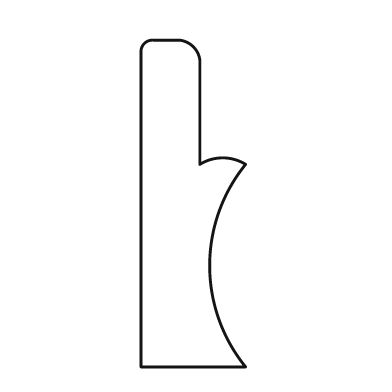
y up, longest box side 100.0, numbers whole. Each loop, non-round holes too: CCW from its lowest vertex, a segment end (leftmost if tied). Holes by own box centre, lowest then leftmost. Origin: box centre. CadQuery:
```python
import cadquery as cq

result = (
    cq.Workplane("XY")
    .moveTo(-16.0, -50.0)
    .lineTo(16.0, -50.0)
    .threePointArc((5.0, -19.0), (16.0, 12.0))
    .threePointArc((9.0, 14.0), (2.0, 12.0))
    .lineTo(2.0, 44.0)
    .threePointArc((0.0, 48.0), (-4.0, 50.0))
    .lineTo(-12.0, 50.0)
    .threePointArc((-15.0, 49.0), (-16.0, 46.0))
    .close()
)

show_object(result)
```